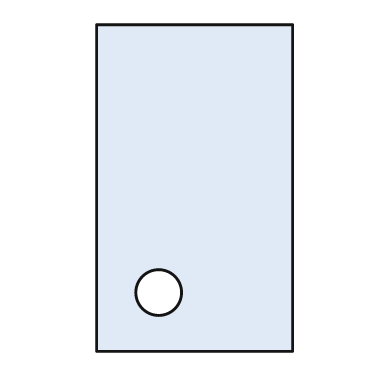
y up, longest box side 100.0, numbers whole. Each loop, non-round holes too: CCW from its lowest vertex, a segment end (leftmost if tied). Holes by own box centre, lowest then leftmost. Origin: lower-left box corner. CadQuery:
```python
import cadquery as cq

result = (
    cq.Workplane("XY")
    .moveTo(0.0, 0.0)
    .lineTo(60.0, 0.0)
    .lineTo(60.0, 100.0)
    .lineTo(0.0, 100.0)
    .close()
    .moveTo(19.0, 18.0)
    .circle(7.0)
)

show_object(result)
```